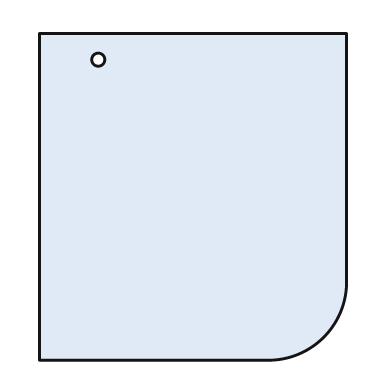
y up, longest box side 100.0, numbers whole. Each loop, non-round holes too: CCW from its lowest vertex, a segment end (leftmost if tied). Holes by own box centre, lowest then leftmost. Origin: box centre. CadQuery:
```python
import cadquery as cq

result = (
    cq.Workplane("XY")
    .moveTo(-47.0, -50.0)
    .lineTo(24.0, -50.0)
    .threePointArc((40.0, -43.0), (47.0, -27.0))
    .lineTo(47.0, 50.0)
    .lineTo(-47.0, 50.0)
    .close()
    .moveTo(-29.0, 42.0)
    .circle(2.0)
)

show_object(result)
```